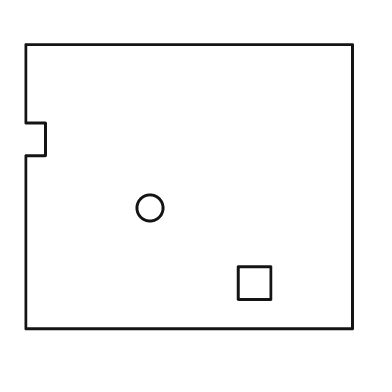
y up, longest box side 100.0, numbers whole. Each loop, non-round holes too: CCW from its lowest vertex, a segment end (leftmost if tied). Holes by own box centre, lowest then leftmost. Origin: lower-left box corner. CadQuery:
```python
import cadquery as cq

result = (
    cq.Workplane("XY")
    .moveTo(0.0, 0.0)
    .lineTo(100.0, 0.0)
    .lineTo(100.0, 87.0)
    .lineTo(0.0, 87.0)
    .lineTo(0.0, 63.0)
    .lineTo(6.0, 63.0)
    .lineTo(6.0, 53.0)
    .lineTo(0.0, 53.0)
    .close()
    .moveTo(65.0, 9.0)
    .lineTo(75.0, 9.0)
    .lineTo(75.0, 19.0)
    .lineTo(65.0, 19.0)
    .close()
    .moveTo(38.0, 37.0)
    .circle(4.0)
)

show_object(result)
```